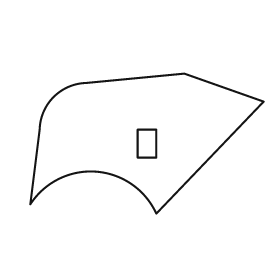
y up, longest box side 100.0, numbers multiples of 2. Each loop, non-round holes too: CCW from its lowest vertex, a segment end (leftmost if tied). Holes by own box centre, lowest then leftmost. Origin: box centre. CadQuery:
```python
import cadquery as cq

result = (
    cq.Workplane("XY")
    .moveTo(4.0, -30.0)
    .lineTo(50.0, 18.0)
    .lineTo(16.0, 30.0)
    .lineTo(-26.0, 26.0)
    .threePointArc((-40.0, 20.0), (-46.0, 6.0))
    .lineTo(-50.0, -26.0)
    .threePointArc((-22.0, -12.0), (4.0, -30.0))
    .close()
    .moveTo(-4.0, -6.0)
    .lineTo(4.0, -6.0)
    .lineTo(4.0, 6.0)
    .lineTo(-4.0, 6.0)
    .close()
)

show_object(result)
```